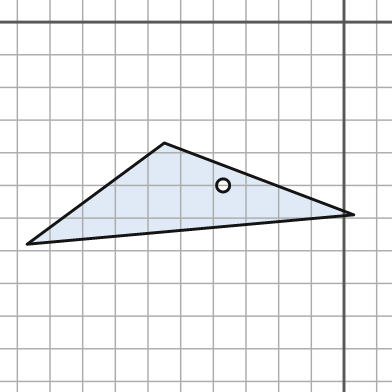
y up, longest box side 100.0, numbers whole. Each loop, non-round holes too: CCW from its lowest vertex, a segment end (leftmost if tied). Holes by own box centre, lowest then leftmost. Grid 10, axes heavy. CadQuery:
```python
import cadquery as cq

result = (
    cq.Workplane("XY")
    .moveTo(-97.0, -68.0)
    .lineTo(3.0, -59.0)
    .lineTo(-55.0, -37.0)
    .close()
    .moveTo(-37.0, -50.0)
    .circle(2.0)
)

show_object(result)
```